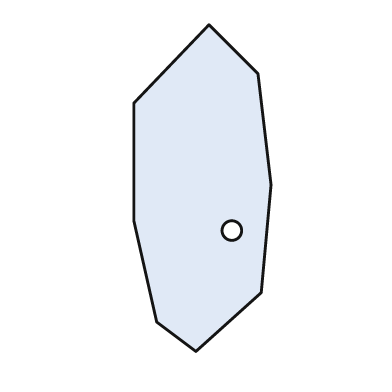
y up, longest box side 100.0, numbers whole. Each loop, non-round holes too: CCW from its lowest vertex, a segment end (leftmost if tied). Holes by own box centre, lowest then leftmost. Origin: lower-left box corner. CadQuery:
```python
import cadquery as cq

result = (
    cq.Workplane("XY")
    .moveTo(19.0, 0.0)
    .lineTo(39.0, 18.0)
    .lineTo(42.0, 51.0)
    .lineTo(38.0, 85.0)
    .lineTo(23.0, 100.0)
    .lineTo(0.0, 76.0)
    .lineTo(0.0, 40.0)
    .lineTo(7.0, 9.0)
    .close()
    .moveTo(30.0, 37.0)
    .circle(3.0)
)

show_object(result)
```